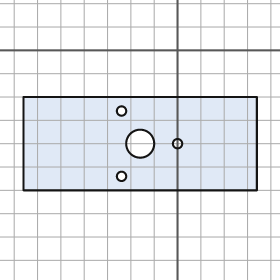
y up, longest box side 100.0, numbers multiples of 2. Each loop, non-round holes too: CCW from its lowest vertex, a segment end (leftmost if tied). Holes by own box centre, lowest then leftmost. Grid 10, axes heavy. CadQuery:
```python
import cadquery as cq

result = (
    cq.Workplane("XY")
    .moveTo(-66.0, -60.0)
    .lineTo(34.0, -60.0)
    .lineTo(34.0, -20.0)
    .lineTo(-66.0, -20.0)
    .close()
    .moveTo(-24.0, -54.0)
    .circle(2.0)
    .moveTo(-16.0, -40.0)
    .circle(6.0)
    .moveTo(0.0, -40.0)
    .circle(2.0)
    .moveTo(-24.0, -26.0)
    .circle(2.0)
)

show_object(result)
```